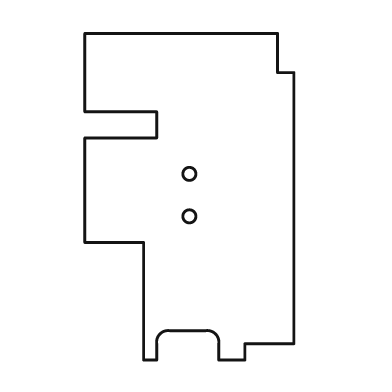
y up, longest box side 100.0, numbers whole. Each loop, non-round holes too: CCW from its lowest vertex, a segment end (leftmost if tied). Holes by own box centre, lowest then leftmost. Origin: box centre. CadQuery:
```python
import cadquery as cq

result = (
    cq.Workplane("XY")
    .moveTo(-14.0, -50.0)
    .lineTo(-10.0, -50.0)
    .lineTo(-10.0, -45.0)
    .threePointArc((-9.0, -42.0), (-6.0, -41.0))
    .lineTo(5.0, -41.0)
    .threePointArc((8.0, -42.0), (9.0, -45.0))
    .lineTo(9.0, -50.0)
    .lineTo(17.0, -50.0)
    .lineTo(17.0, -45.0)
    .lineTo(32.0, -45.0)
    .lineTo(32.0, 38.0)
    .lineTo(27.0, 38.0)
    .lineTo(27.0, 50.0)
    .lineTo(-32.0, 50.0)
    .lineTo(-32.0, 26.0)
    .lineTo(-10.0, 26.0)
    .lineTo(-10.0, 18.0)
    .lineTo(-32.0, 18.0)
    .lineTo(-32.0, -14.0)
    .lineTo(-14.0, -14.0)
    .close()
    .moveTo(0.0, -6.0)
    .circle(2.0)
    .moveTo(0.0, 7.0)
    .circle(2.0)
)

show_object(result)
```